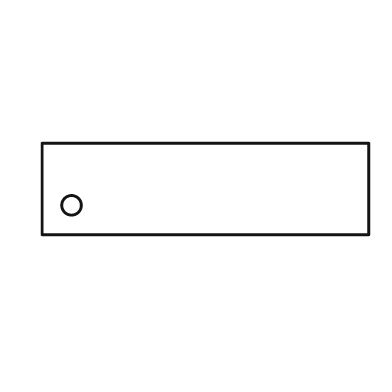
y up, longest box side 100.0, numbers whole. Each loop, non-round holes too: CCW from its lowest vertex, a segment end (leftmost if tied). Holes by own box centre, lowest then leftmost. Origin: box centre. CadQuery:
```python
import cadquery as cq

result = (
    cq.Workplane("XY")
    .moveTo(-50.0, -14.0)
    .lineTo(50.0, -14.0)
    .lineTo(50.0, 14.0)
    .lineTo(-50.0, 14.0)
    .close()
    .moveTo(-41.0, -5.0)
    .circle(3.0)
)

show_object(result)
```